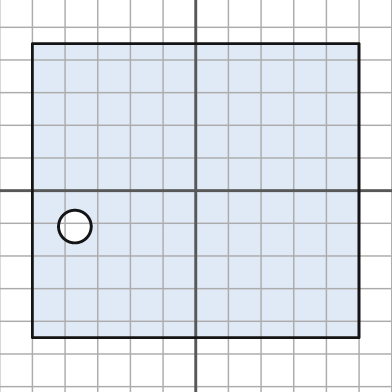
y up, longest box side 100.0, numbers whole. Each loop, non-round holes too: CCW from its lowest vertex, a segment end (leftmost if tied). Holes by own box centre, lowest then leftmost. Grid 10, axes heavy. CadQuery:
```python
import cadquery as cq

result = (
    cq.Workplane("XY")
    .moveTo(-50.0, -45.0)
    .lineTo(50.0, -45.0)
    .lineTo(50.0, 45.0)
    .lineTo(-50.0, 45.0)
    .close()
    .moveTo(-37.0, -11.0)
    .circle(5.0)
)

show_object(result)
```